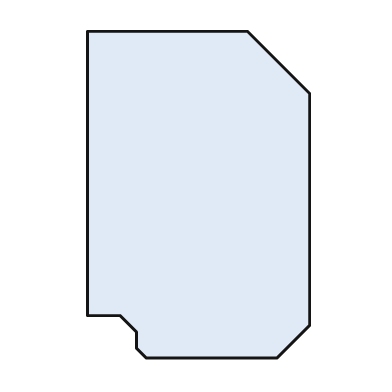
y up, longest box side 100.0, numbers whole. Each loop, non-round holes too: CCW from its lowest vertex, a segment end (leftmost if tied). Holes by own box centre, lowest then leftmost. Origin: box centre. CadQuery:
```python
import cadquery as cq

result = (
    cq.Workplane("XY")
    .moveTo(-16.0, -50.0)
    .lineTo(24.0, -50.0)
    .lineTo(34.0, -40.0)
    .lineTo(34.0, 31.0)
    .lineTo(15.0, 50.0)
    .lineTo(-34.0, 50.0)
    .lineTo(-34.0, -37.0)
    .lineTo(-24.0, -37.0)
    .lineTo(-19.0, -42.0)
    .lineTo(-19.0, -47.0)
    .close()
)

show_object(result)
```